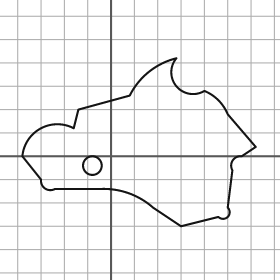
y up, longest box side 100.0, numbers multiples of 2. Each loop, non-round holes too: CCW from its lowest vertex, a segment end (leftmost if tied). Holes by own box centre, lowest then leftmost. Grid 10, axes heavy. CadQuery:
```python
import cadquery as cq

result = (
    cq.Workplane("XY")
    .moveTo(30.0, -30.0)
    .lineTo(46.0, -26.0)
    .threePointArc((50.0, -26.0), (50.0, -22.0))
    .lineTo(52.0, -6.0)
    .threePointArc((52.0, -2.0), (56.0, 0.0))
    .lineTo(62.0, 4.0)
    .lineTo(50.0, 18.0)
    .threePointArc((46.0, 24.0), (40.0, 28.0))
    .threePointArc((28.0, 30.0), (28.0, 42.0))
    .threePointArc((16.0, 36.0), (8.0, 26.0))
    .lineTo(-14.0, 20.0)
    .lineTo(-16.0, 12.0)
    .threePointArc((-30.0, 12.0), (-38.0, 0.0))
    .lineTo(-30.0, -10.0)
    .threePointArc((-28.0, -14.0), (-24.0, -14.0))
    .lineTo(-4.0, -14.0)
    .threePointArc((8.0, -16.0), (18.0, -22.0))
    .close()
    .moveTo(-8.0, -4.0)
    .circle(4.0)
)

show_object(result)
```